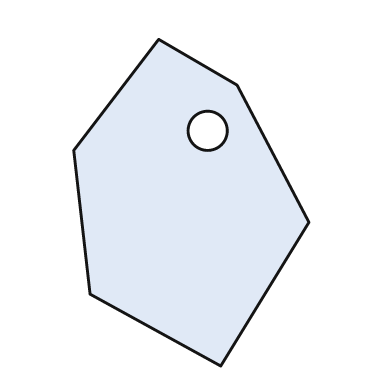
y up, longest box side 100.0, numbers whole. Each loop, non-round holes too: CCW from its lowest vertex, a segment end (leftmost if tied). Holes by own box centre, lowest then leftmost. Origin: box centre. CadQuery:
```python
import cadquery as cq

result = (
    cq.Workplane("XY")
    .moveTo(9.0, -50.0)
    .lineTo(36.0, -6.0)
    .lineTo(14.0, 36.0)
    .lineTo(-10.0, 50.0)
    .lineTo(-36.0, 16.0)
    .lineTo(-31.0, -28.0)
    .close()
    .moveTo(5.0, 22.0)
    .circle(6.0)
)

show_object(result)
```